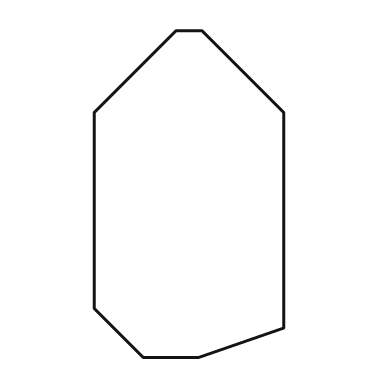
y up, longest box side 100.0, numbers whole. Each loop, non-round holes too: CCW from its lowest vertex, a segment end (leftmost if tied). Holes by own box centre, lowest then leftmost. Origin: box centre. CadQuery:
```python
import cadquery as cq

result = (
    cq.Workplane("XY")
    .moveTo(-14.0, -50.0)
    .lineTo(3.0, -50.0)
    .lineTo(29.0, -41.0)
    .lineTo(29.0, 25.0)
    .lineTo(4.0, 50.0)
    .lineTo(-4.0, 50.0)
    .lineTo(-29.0, 25.0)
    .lineTo(-29.0, -35.0)
    .close()
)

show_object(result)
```